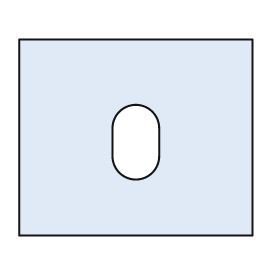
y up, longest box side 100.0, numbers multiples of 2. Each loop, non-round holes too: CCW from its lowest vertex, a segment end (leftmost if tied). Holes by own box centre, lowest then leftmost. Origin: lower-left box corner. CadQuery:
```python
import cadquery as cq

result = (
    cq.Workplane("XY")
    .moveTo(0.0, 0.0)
    .lineTo(100.0, 0.0)
    .lineTo(100.0, 84.0)
    .lineTo(0.0, 84.0)
    .close()
    .moveTo(40.0, 34.0)
    .threePointArc((50.0, 24.0), (60.0, 34.0))
    .lineTo(60.0, 46.0)
    .threePointArc((50.0, 56.0), (40.0, 46.0))
    .close()
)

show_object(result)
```